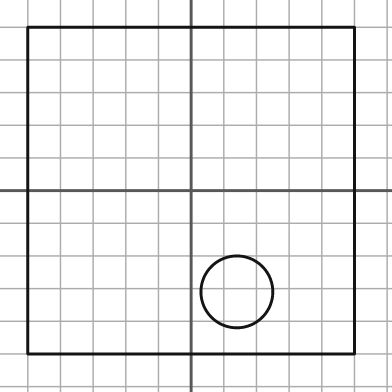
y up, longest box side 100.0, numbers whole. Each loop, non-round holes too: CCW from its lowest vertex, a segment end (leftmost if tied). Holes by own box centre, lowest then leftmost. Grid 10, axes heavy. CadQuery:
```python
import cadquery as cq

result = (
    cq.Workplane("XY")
    .moveTo(-50.0, -50.0)
    .lineTo(50.0, -50.0)
    .lineTo(50.0, 50.0)
    .lineTo(-50.0, 50.0)
    .close()
    .moveTo(14.0, -31.0)
    .circle(11.0)
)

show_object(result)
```